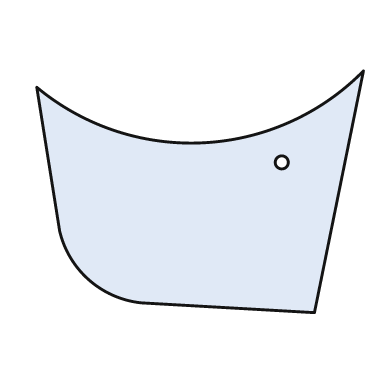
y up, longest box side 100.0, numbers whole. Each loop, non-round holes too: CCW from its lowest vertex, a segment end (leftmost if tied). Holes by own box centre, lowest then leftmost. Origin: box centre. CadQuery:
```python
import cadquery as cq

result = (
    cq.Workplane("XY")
    .moveTo(35.0, -37.0)
    .lineTo(50.0, 37.0)
    .threePointArc((1.0, 15.0), (-50.0, 32.0))
    .lineTo(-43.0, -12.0)
    .threePointArc((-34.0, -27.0), (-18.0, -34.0))
    .close()
    .moveTo(25.0, 9.0)
    .circle(2.0)
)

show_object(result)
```